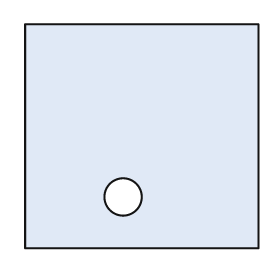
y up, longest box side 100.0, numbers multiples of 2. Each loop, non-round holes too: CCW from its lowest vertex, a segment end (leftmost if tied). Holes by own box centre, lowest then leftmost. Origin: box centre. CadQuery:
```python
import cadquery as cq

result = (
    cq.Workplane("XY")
    .moveTo(-50.0, -48.0)
    .lineTo(50.0, -48.0)
    .lineTo(50.0, 48.0)
    .lineTo(-50.0, 48.0)
    .close()
    .moveTo(-8.0, -26.0)
    .circle(8.0)
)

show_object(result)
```